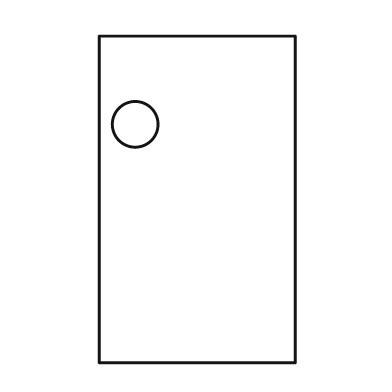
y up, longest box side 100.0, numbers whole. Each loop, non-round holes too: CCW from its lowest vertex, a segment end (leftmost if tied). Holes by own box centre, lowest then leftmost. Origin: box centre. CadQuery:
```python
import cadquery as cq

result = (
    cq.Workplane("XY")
    .moveTo(-30.0, -50.0)
    .lineTo(30.0, -50.0)
    .lineTo(30.0, 50.0)
    .lineTo(-30.0, 50.0)
    .close()
    .moveTo(-19.0, 23.0)
    .circle(7.0)
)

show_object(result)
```